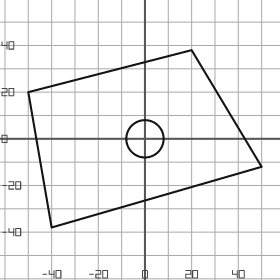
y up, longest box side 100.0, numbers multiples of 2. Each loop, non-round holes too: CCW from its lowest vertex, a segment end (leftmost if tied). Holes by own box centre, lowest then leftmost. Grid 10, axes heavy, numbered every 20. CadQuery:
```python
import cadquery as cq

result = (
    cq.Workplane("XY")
    .moveTo(-40.0, -38.0)
    .lineTo(50.0, -12.0)
    .lineTo(20.0, 38.0)
    .lineTo(-50.0, 20.0)
    .close()
    .moveTo(0.0, 0.0)
    .circle(8.0)
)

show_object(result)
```